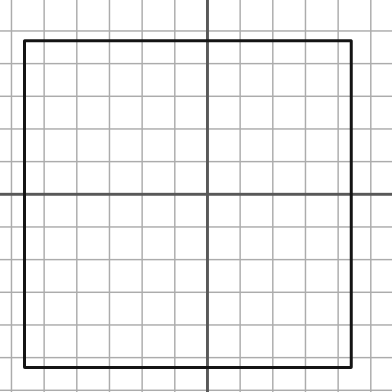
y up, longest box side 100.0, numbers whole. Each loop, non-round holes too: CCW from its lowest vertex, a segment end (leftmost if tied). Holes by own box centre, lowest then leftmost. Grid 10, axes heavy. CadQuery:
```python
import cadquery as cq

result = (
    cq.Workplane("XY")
    .moveTo(-56.0, -53.0)
    .lineTo(44.0, -53.0)
    .lineTo(44.0, 47.0)
    .lineTo(-56.0, 47.0)
    .close()
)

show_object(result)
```